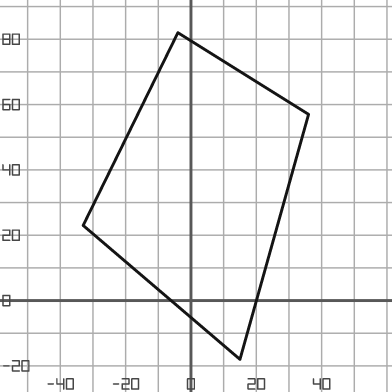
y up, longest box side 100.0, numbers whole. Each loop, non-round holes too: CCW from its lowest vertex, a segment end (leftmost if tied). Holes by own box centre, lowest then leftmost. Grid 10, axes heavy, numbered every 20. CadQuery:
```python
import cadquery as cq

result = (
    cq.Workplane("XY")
    .moveTo(15.0, -18.0)
    .lineTo(36.0, 57.0)
    .lineTo(-4.0, 82.0)
    .lineTo(-33.0, 23.0)
    .close()
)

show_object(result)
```